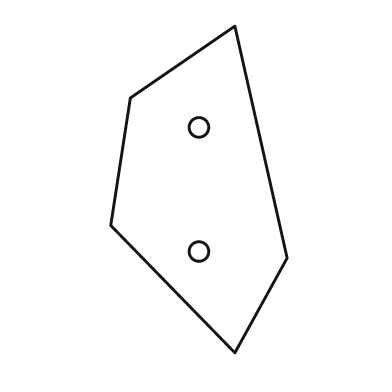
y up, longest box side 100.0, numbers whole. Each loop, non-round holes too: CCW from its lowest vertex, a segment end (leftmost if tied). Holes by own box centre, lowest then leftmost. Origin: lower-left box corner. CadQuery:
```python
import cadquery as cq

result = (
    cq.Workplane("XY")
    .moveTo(38.0, 0.0)
    .lineTo(54.0, 29.0)
    .lineTo(38.0, 100.0)
    .lineTo(6.0, 78.0)
    .lineTo(0.0, 39.0)
    .close()
    .moveTo(27.0, 31.0)
    .circle(3.0)
    .moveTo(27.0, 69.0)
    .circle(3.0)
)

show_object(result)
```